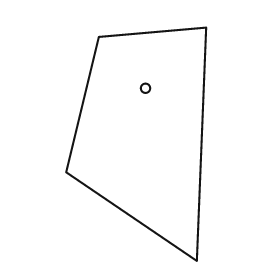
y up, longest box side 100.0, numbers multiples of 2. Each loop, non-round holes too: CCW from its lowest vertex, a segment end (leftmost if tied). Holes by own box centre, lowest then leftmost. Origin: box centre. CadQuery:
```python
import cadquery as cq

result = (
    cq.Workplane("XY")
    .moveTo(26.0, -50.0)
    .lineTo(30.0, 50.0)
    .lineTo(-16.0, 46.0)
    .lineTo(-30.0, -12.0)
    .close()
    .moveTo(4.0, 24.0)
    .circle(2.0)
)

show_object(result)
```